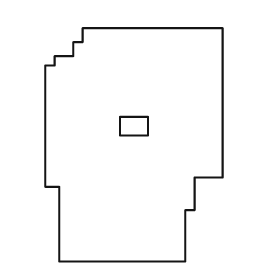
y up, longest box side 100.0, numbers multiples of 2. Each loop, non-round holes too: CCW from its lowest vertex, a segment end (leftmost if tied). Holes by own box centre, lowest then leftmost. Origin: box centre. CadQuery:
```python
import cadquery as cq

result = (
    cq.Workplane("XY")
    .moveTo(-32.0, -50.0)
    .lineTo(22.0, -50.0)
    .lineTo(22.0, -28.0)
    .lineTo(26.0, -28.0)
    .lineTo(26.0, -14.0)
    .lineTo(38.0, -14.0)
    .lineTo(38.0, 50.0)
    .lineTo(-22.0, 50.0)
    .lineTo(-22.0, 44.0)
    .lineTo(-26.0, 44.0)
    .lineTo(-26.0, 38.0)
    .lineTo(-34.0, 38.0)
    .lineTo(-34.0, 34.0)
    .lineTo(-38.0, 34.0)
    .lineTo(-38.0, -18.0)
    .lineTo(-32.0, -18.0)
    .close()
    .moveTo(-6.0, 4.0)
    .lineTo(6.0, 4.0)
    .lineTo(6.0, 12.0)
    .lineTo(-6.0, 12.0)
    .close()
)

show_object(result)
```